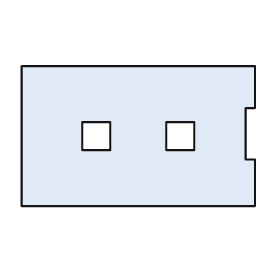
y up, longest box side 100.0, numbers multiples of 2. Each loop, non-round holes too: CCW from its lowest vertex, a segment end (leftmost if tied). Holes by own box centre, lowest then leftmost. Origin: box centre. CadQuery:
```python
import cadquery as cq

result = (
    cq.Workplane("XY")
    .moveTo(-50.0, -30.0)
    .lineTo(50.0, -30.0)
    .lineTo(50.0, -10.0)
    .lineTo(46.0, -10.0)
    .lineTo(46.0, 12.0)
    .lineTo(50.0, 12.0)
    .lineTo(50.0, 30.0)
    .lineTo(-50.0, 30.0)
    .close()
    .moveTo(-24.0, -6.0)
    .lineTo(-12.0, -6.0)
    .lineTo(-12.0, 6.0)
    .lineTo(-24.0, 6.0)
    .close()
    .moveTo(12.0, -6.0)
    .lineTo(24.0, -6.0)
    .lineTo(24.0, 6.0)
    .lineTo(12.0, 6.0)
    .close()
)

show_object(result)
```